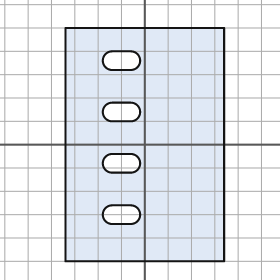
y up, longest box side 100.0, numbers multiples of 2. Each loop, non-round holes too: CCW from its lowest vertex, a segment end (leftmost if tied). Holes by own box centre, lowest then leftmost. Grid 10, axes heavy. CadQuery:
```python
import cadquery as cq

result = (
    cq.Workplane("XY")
    .moveTo(-34.0, -50.0)
    .lineTo(34.0, -50.0)
    .lineTo(34.0, 50.0)
    .lineTo(-34.0, 50.0)
    .close()
    .moveTo(-14.0, -34.0)
    .lineTo(-6.0, -34.0)
    .threePointArc((-2.0, -30.0), (-6.0, -26.0))
    .lineTo(-14.0, -26.0)
    .threePointArc((-18.0, -30.0), (-14.0, -34.0))
    .close()
    .moveTo(-14.0, -12.0)
    .lineTo(-6.0, -12.0)
    .threePointArc((-2.0, -8.0), (-6.0, -4.0))
    .lineTo(-14.0, -4.0)
    .threePointArc((-18.0, -8.0), (-14.0, -12.0))
    .close()
    .moveTo(-14.0, 10.0)
    .lineTo(-6.0, 10.0)
    .threePointArc((-2.0, 14.0), (-6.0, 18.0))
    .lineTo(-14.0, 18.0)
    .threePointArc((-18.0, 14.0), (-14.0, 10.0))
    .close()
    .moveTo(-14.0, 32.0)
    .lineTo(-6.0, 32.0)
    .threePointArc((-2.0, 36.0), (-6.0, 40.0))
    .lineTo(-14.0, 40.0)
    .threePointArc((-18.0, 36.0), (-14.0, 32.0))
    .close()
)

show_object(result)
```